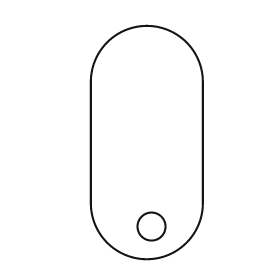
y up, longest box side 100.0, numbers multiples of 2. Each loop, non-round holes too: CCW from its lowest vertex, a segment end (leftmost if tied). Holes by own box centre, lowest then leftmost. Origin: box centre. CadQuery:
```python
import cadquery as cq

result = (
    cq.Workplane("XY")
    .moveTo(-24.0, -26.0)
    .threePointArc((0.0, -50.0), (24.0, -26.0))
    .lineTo(24.0, 26.0)
    .threePointArc((0.0, 50.0), (-24.0, 26.0))
    .close()
    .moveTo(2.0, -36.0)
    .circle(6.0)
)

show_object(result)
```